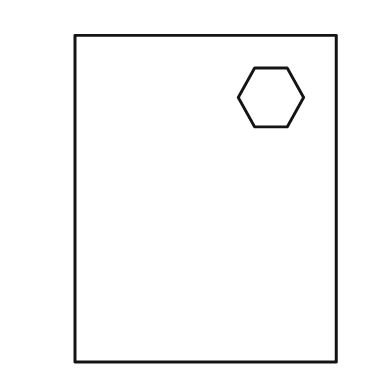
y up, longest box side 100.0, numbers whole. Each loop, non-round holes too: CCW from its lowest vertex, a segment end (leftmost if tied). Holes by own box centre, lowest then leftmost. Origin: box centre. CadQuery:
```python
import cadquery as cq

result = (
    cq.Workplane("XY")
    .moveTo(-40.0, -50.0)
    .lineTo(40.0, -50.0)
    .lineTo(40.0, 50.0)
    .lineTo(-40.0, 50.0)
    .close()
    .moveTo(15.0, 22.0)
    .lineTo(25.0, 22.0)
    .lineTo(30.0, 31.0)
    .lineTo(25.0, 40.0)
    .lineTo(15.0, 40.0)
    .lineTo(10.0, 31.0)
    .close()
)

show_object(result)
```